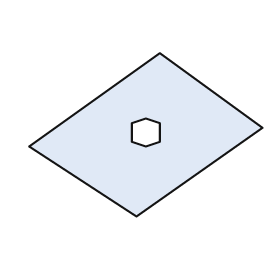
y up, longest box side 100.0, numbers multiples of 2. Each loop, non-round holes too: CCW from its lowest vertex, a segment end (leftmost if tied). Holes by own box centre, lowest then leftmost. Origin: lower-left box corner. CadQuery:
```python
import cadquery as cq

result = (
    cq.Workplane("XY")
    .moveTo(46.0, 0.0)
    .lineTo(100.0, 38.0)
    .lineTo(56.0, 70.0)
    .lineTo(0.0, 30.0)
    .close()
    .moveTo(50.0, 30.0)
    .lineTo(56.0, 32.0)
    .lineTo(56.0, 40.0)
    .lineTo(50.0, 42.0)
    .lineTo(44.0, 40.0)
    .lineTo(44.0, 32.0)
    .close()
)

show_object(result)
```